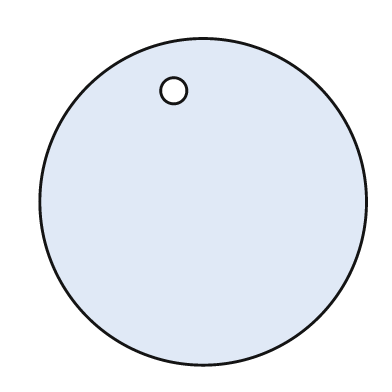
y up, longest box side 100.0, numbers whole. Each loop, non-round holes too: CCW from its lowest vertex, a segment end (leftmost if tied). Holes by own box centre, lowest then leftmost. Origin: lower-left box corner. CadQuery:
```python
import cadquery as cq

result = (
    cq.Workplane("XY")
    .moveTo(50.0, 50.0)
    .circle(50.0)
    .moveTo(41.0, 84.0)
    .circle(4.0)
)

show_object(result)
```